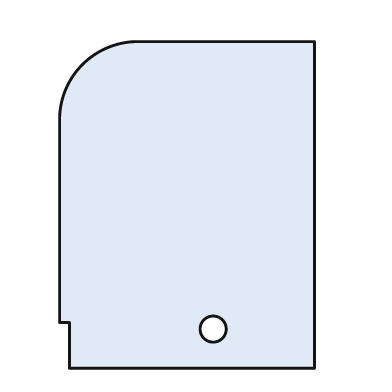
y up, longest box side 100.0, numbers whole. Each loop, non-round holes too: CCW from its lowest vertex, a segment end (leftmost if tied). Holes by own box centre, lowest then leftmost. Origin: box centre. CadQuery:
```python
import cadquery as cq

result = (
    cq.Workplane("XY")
    .moveTo(-36.0, -50.0)
    .lineTo(39.0, -50.0)
    .lineTo(39.0, 50.0)
    .lineTo(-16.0, 50.0)
    .threePointArc((-32.0, 43.0), (-39.0, 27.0))
    .lineTo(-39.0, -36.0)
    .lineTo(-36.0, -36.0)
    .close()
    .moveTo(8.0, -38.0)
    .circle(4.0)
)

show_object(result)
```